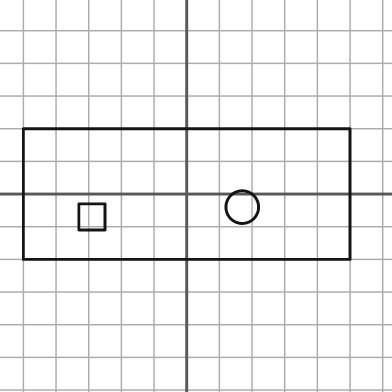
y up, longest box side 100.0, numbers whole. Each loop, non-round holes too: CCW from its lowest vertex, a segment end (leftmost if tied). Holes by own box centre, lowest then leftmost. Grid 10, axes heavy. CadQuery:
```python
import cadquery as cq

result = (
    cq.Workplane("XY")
    .moveTo(-50.0, -20.0)
    .lineTo(50.0, -20.0)
    .lineTo(50.0, 20.0)
    .lineTo(-50.0, 20.0)
    .close()
    .moveTo(-33.0, -11.0)
    .lineTo(-25.0, -11.0)
    .lineTo(-25.0, -3.0)
    .lineTo(-33.0, -3.0)
    .close()
    .moveTo(17.0, -4.0)
    .circle(5.0)
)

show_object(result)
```